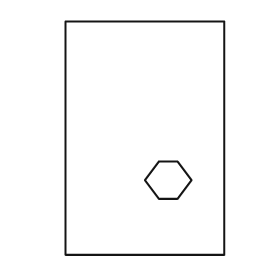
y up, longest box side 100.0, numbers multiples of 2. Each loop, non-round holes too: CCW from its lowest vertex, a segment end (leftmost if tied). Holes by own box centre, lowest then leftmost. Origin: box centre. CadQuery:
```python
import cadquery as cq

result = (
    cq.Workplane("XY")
    .moveTo(-34.0, -50.0)
    .lineTo(34.0, -50.0)
    .lineTo(34.0, 50.0)
    .lineTo(-34.0, 50.0)
    .close()
    .moveTo(6.0, -26.0)
    .lineTo(14.0, -26.0)
    .lineTo(20.0, -18.0)
    .lineTo(14.0, -10.0)
    .lineTo(6.0, -10.0)
    .lineTo(0.0, -18.0)
    .close()
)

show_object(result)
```